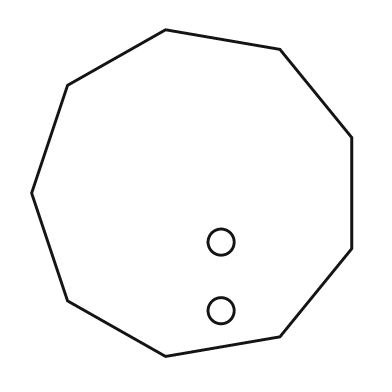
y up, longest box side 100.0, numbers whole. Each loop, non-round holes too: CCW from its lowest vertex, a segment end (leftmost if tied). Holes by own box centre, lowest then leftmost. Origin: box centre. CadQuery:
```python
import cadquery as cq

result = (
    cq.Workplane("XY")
    .moveTo(-8.0, -50.0)
    .lineTo(27.0, -44.0)
    .lineTo(49.0, -17.0)
    .lineTo(49.0, 17.0)
    .lineTo(27.0, 44.0)
    .lineTo(-8.0, 50.0)
    .lineTo(-38.0, 33.0)
    .lineTo(-49.0, 0.0)
    .lineTo(-38.0, -33.0)
    .close()
    .moveTo(9.0, -36.0)
    .circle(4.0)
    .moveTo(9.0, -15.0)
    .circle(4.0)
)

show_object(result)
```